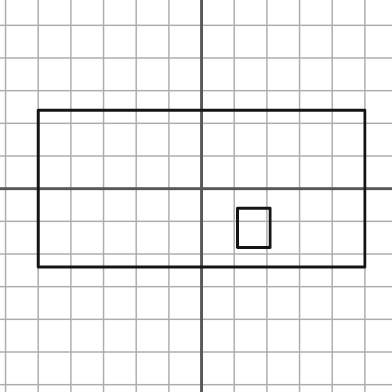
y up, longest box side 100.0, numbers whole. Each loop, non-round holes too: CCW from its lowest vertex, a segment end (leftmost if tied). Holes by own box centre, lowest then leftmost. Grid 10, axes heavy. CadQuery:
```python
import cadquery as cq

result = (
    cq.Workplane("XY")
    .moveTo(-50.0, -24.0)
    .lineTo(50.0, -24.0)
    .lineTo(50.0, 24.0)
    .lineTo(-50.0, 24.0)
    .close()
    .moveTo(11.0, -18.0)
    .lineTo(21.0, -18.0)
    .lineTo(21.0, -6.0)
    .lineTo(11.0, -6.0)
    .close()
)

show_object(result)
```